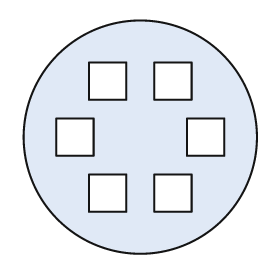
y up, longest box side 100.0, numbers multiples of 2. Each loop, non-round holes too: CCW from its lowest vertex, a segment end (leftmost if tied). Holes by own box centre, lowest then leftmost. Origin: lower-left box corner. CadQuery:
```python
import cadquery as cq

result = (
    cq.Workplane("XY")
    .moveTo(50.0, 50.0)
    .circle(50.0)
    .moveTo(28.0, 18.0)
    .lineTo(44.0, 18.0)
    .lineTo(44.0, 34.0)
    .lineTo(28.0, 34.0)
    .close()
    .moveTo(56.0, 18.0)
    .lineTo(72.0, 18.0)
    .lineTo(72.0, 34.0)
    .lineTo(56.0, 34.0)
    .close()
    .moveTo(14.0, 42.0)
    .lineTo(30.0, 42.0)
    .lineTo(30.0, 58.0)
    .lineTo(14.0, 58.0)
    .close()
    .moveTo(70.0, 42.0)
    .lineTo(86.0, 42.0)
    .lineTo(86.0, 58.0)
    .lineTo(70.0, 58.0)
    .close()
    .moveTo(28.0, 66.0)
    .lineTo(44.0, 66.0)
    .lineTo(44.0, 82.0)
    .lineTo(28.0, 82.0)
    .close()
    .moveTo(56.0, 66.0)
    .lineTo(72.0, 66.0)
    .lineTo(72.0, 82.0)
    .lineTo(56.0, 82.0)
    .close()
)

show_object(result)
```